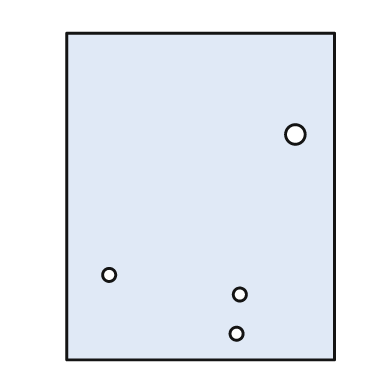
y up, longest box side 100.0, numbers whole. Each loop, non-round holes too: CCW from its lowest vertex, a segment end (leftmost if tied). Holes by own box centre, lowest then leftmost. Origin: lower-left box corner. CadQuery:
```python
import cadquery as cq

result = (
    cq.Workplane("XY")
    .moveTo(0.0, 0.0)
    .lineTo(82.0, 0.0)
    .lineTo(82.0, 100.0)
    .lineTo(0.0, 100.0)
    .close()
    .moveTo(52.0, 8.0)
    .circle(2.0)
    .moveTo(53.0, 20.0)
    .circle(2.0)
    .moveTo(13.0, 26.0)
    .circle(2.0)
    .moveTo(70.0, 69.0)
    .circle(3.0)
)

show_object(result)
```